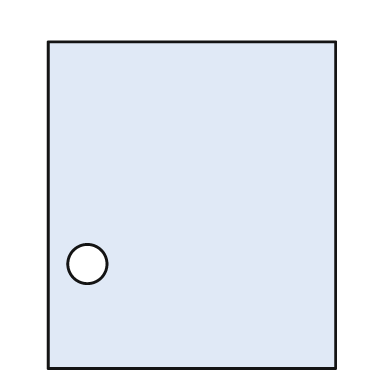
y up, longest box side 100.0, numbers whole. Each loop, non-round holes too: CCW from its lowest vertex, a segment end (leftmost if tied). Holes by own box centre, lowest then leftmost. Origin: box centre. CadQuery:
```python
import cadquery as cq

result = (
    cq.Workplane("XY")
    .moveTo(-44.0, -50.0)
    .lineTo(44.0, -50.0)
    .lineTo(44.0, 50.0)
    .lineTo(-44.0, 50.0)
    .close()
    .moveTo(-32.0, -18.0)
    .circle(6.0)
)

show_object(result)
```